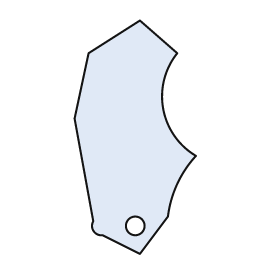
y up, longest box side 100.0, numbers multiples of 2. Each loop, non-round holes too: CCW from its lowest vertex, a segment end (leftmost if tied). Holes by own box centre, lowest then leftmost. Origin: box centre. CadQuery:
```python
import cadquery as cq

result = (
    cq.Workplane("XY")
    .moveTo(2.0, -50.0)
    .lineTo(14.0, -34.0)
    .threePointArc((18.0, -20.0), (26.0, -8.0))
    .threePointArc((12.0, 12.0), (18.0, 36.0))
    .lineTo(2.0, 50.0)
    .lineTo(-20.0, 36.0)
    .lineTo(-26.0, 8.0)
    .lineTo(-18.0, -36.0)
    .threePointArc((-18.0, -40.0), (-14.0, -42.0))
    .close()
    .moveTo(0.0, -38.0)
    .circle(4.0)
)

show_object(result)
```